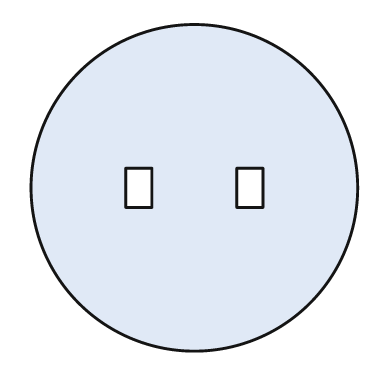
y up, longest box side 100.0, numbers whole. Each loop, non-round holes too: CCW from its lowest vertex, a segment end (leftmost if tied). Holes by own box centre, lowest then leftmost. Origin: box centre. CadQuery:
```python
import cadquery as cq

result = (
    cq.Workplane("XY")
    .moveTo(0.0, 0.0)
    .circle(50.0)
    .moveTo(-21.0, -6.0)
    .lineTo(-13.0, -6.0)
    .lineTo(-13.0, 6.0)
    .lineTo(-21.0, 6.0)
    .close()
    .moveTo(13.0, -6.0)
    .lineTo(21.0, -6.0)
    .lineTo(21.0, 6.0)
    .lineTo(13.0, 6.0)
    .close()
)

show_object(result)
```